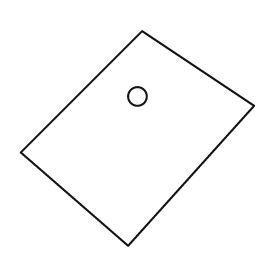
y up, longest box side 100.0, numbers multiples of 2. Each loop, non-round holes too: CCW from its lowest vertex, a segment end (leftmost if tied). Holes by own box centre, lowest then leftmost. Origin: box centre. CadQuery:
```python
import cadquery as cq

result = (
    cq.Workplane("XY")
    .moveTo(-4.0, -46.0)
    .lineTo(50.0, 14.0)
    .lineTo(2.0, 46.0)
    .lineTo(-50.0, -6.0)
    .close()
    .moveTo(0.0, 18.0)
    .circle(4.0)
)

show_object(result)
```